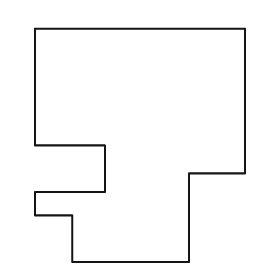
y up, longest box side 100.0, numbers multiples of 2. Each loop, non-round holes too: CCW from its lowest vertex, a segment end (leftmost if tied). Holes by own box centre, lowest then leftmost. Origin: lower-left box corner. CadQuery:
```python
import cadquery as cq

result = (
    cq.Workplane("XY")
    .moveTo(16.0, 0.0)
    .lineTo(66.0, 0.0)
    .lineTo(66.0, 38.0)
    .lineTo(90.0, 38.0)
    .lineTo(90.0, 100.0)
    .lineTo(0.0, 100.0)
    .lineTo(0.0, 50.0)
    .lineTo(30.0, 50.0)
    .lineTo(30.0, 30.0)
    .lineTo(0.0, 30.0)
    .lineTo(0.0, 20.0)
    .lineTo(16.0, 20.0)
    .close()
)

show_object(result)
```